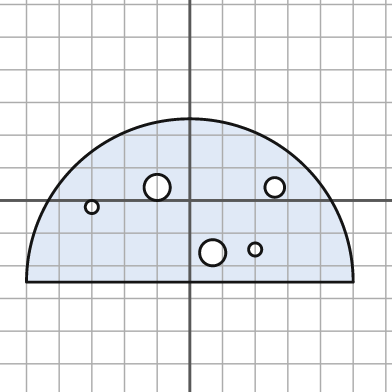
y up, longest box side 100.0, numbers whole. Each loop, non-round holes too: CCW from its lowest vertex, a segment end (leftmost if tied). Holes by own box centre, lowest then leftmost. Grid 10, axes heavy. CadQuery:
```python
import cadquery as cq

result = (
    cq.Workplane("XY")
    .moveTo(-50.0, -25.0)
    .lineTo(50.0, -25.0)
    .threePointArc((0.0, 25.0), (-50.0, -25.0))
    .close()
    .moveTo(7.0, -16.0)
    .circle(4.0)
    .moveTo(20.0, -15.0)
    .circle(2.0)
    .moveTo(-30.0, -2.0)
    .circle(2.0)
    .moveTo(-10.0, 4.0)
    .circle(4.0)
    .moveTo(26.0, 4.0)
    .circle(3.0)
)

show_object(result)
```